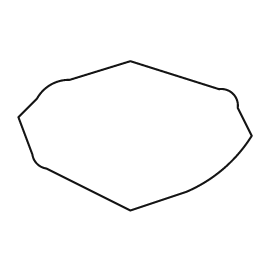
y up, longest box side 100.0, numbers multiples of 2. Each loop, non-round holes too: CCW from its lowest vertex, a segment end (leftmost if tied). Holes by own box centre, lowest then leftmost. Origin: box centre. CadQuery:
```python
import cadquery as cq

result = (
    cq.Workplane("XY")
    .moveTo(-2.0, -32.0)
    .lineTo(22.0, -24.0)
    .threePointArc((38.0, -14.0), (50.0, 0.0))
    .lineTo(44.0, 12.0)
    .threePointArc((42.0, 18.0), (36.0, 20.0))
    .lineTo(-2.0, 32.0)
    .lineTo(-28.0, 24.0)
    .threePointArc((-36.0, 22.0), (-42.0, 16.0))
    .lineTo(-50.0, 8.0)
    .lineTo(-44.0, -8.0)
    .threePointArc((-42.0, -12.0), (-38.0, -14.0))
    .close()
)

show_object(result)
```